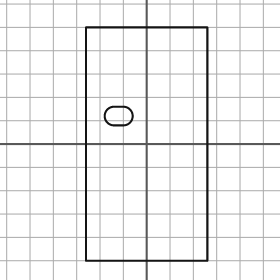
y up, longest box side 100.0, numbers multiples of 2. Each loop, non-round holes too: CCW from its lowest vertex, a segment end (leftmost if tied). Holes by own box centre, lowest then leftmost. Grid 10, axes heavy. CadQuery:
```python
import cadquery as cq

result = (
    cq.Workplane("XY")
    .moveTo(-26.0, -50.0)
    .lineTo(26.0, -50.0)
    .lineTo(26.0, 50.0)
    .lineTo(-26.0, 50.0)
    .close()
    .moveTo(-14.0, 8.0)
    .lineTo(-10.0, 8.0)
    .threePointArc((-6.0, 12.0), (-10.0, 16.0))
    .lineTo(-14.0, 16.0)
    .threePointArc((-18.0, 12.0), (-14.0, 8.0))
    .close()
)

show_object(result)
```